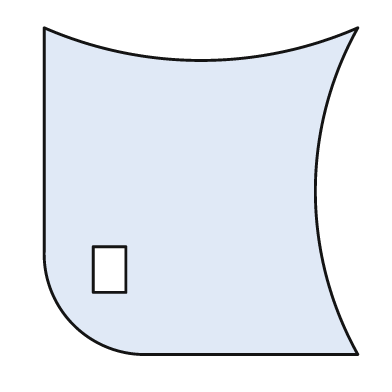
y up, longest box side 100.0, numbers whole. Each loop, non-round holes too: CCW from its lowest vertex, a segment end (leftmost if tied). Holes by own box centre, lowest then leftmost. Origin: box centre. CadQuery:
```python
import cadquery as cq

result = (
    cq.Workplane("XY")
    .moveTo(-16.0, -50.0)
    .lineTo(48.0, -50.0)
    .threePointArc((35.0, 0.0), (48.0, 50.0))
    .threePointArc((0.0, 40.0), (-48.0, 50.0))
    .lineTo(-48.0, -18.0)
    .threePointArc((-39.0, -41.0), (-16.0, -50.0))
    .close()
    .moveTo(-33.0, -31.0)
    .lineTo(-23.0, -31.0)
    .lineTo(-23.0, -17.0)
    .lineTo(-33.0, -17.0)
    .close()
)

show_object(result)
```